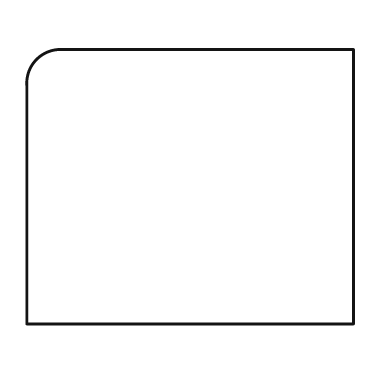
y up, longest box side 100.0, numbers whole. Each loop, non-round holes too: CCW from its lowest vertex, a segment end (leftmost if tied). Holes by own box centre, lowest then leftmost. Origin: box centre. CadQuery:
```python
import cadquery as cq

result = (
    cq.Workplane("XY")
    .moveTo(-50.0, -42.0)
    .lineTo(50.0, -42.0)
    .lineTo(50.0, 42.0)
    .lineTo(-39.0, 42.0)
    .threePointArc((-47.0, 39.0), (-50.0, 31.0))
    .close()
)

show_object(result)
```